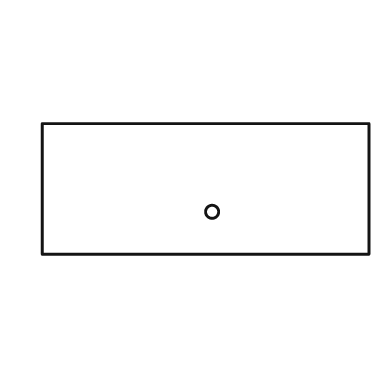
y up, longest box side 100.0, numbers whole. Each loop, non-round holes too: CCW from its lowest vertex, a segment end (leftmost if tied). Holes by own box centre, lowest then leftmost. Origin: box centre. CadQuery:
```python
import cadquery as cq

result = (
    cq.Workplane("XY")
    .moveTo(-50.0, -20.0)
    .lineTo(50.0, -20.0)
    .lineTo(50.0, 20.0)
    .lineTo(-50.0, 20.0)
    .close()
    .moveTo(2.0, -7.0)
    .circle(2.0)
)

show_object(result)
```